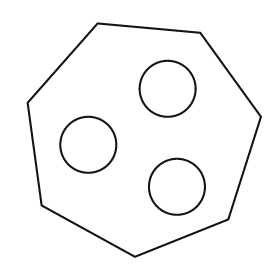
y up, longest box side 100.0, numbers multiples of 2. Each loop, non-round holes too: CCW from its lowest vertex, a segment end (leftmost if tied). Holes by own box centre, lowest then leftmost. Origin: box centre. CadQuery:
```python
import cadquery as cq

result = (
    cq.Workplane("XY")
    .moveTo(-4.0, -50.0)
    .lineTo(36.0, -34.0)
    .lineTo(50.0, 10.0)
    .lineTo(24.0, 46.0)
    .lineTo(-20.0, 50.0)
    .lineTo(-50.0, 16.0)
    .lineTo(-44.0, -28.0)
    .close()
    .moveTo(14.0, -20.0)
    .circle(12.0)
    .moveTo(-24.0, -2.0)
    .circle(12.0)
    .moveTo(10.0, 22.0)
    .circle(12.0)
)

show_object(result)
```